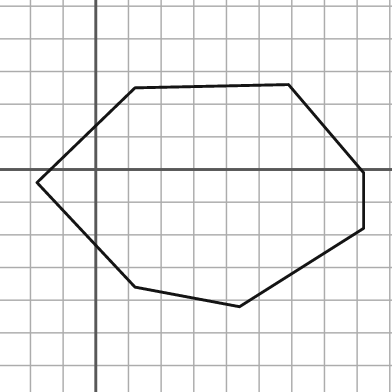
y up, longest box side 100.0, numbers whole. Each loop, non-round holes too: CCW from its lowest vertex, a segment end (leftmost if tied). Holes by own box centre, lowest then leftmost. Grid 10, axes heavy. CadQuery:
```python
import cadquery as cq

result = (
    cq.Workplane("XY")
    .moveTo(44.0, -42.0)
    .lineTo(82.0, -18.0)
    .lineTo(82.0, -1.0)
    .lineTo(59.0, 26.0)
    .lineTo(12.0, 25.0)
    .lineTo(-18.0, -4.0)
    .lineTo(12.0, -36.0)
    .close()
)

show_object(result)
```